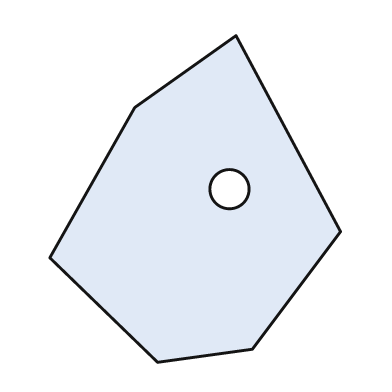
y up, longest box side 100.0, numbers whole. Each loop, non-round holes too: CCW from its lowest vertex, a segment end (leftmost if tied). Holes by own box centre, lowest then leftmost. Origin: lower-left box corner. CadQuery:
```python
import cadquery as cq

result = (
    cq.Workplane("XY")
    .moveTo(33.0, 0.0)
    .lineTo(62.0, 4.0)
    .lineTo(89.0, 40.0)
    .lineTo(57.0, 100.0)
    .lineTo(26.0, 78.0)
    .lineTo(0.0, 32.0)
    .close()
    .moveTo(55.0, 53.0)
    .circle(6.0)
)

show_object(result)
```